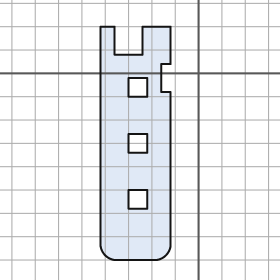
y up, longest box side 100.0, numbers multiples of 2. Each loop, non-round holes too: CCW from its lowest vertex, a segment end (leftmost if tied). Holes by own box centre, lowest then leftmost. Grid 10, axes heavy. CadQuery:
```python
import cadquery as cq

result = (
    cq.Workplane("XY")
    .moveTo(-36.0, -80.0)
    .lineTo(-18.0, -80.0)
    .threePointArc((-14.0, -78.0), (-12.0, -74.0))
    .lineTo(-12.0, -8.0)
    .lineTo(-16.0, -8.0)
    .lineTo(-16.0, 4.0)
    .lineTo(-12.0, 4.0)
    .lineTo(-12.0, 20.0)
    .lineTo(-24.0, 20.0)
    .lineTo(-24.0, 8.0)
    .lineTo(-36.0, 8.0)
    .lineTo(-36.0, 20.0)
    .lineTo(-42.0, 20.0)
    .lineTo(-42.0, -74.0)
    .threePointArc((-40.0, -78.0), (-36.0, -80.0))
    .close()
    .moveTo(-30.0, -58.0)
    .lineTo(-22.0, -58.0)
    .lineTo(-22.0, -50.0)
    .lineTo(-30.0, -50.0)
    .close()
    .moveTo(-30.0, -34.0)
    .lineTo(-22.0, -34.0)
    .lineTo(-22.0, -26.0)
    .lineTo(-30.0, -26.0)
    .close()
    .moveTo(-30.0, -10.0)
    .lineTo(-22.0, -10.0)
    .lineTo(-22.0, -2.0)
    .lineTo(-30.0, -2.0)
    .close()
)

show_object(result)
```